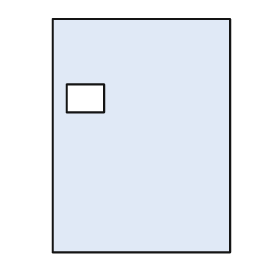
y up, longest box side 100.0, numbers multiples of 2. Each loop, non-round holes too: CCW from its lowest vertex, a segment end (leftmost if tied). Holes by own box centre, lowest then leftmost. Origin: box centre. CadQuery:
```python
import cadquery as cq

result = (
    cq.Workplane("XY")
    .moveTo(-38.0, -50.0)
    .lineTo(38.0, -50.0)
    .lineTo(38.0, 50.0)
    .lineTo(-38.0, 50.0)
    .close()
    .moveTo(-32.0, 10.0)
    .lineTo(-16.0, 10.0)
    .lineTo(-16.0, 22.0)
    .lineTo(-32.0, 22.0)
    .close()
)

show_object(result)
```